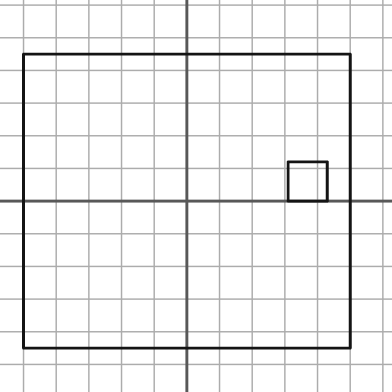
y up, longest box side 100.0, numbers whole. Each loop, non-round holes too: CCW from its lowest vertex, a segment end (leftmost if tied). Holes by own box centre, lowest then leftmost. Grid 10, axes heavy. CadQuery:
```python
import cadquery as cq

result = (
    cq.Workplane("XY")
    .moveTo(-50.0, -45.0)
    .lineTo(50.0, -45.0)
    .lineTo(50.0, 45.0)
    .lineTo(-50.0, 45.0)
    .close()
    .moveTo(31.0, 0.0)
    .lineTo(43.0, 0.0)
    .lineTo(43.0, 12.0)
    .lineTo(31.0, 12.0)
    .close()
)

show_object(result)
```